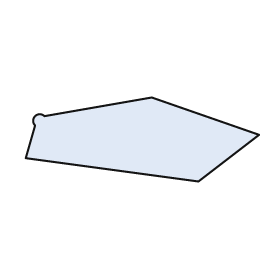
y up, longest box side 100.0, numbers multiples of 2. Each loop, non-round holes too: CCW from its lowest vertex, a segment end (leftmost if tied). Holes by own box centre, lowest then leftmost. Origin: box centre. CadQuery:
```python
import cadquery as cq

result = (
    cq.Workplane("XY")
    .moveTo(24.0, -18.0)
    .lineTo(50.0, 2.0)
    .lineTo(4.0, 18.0)
    .lineTo(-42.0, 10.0)
    .threePointArc((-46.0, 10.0), (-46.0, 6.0))
    .lineTo(-50.0, -8.0)
    .close()
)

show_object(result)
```